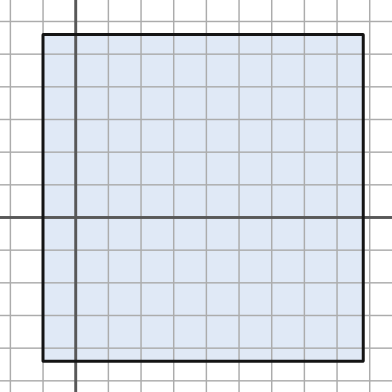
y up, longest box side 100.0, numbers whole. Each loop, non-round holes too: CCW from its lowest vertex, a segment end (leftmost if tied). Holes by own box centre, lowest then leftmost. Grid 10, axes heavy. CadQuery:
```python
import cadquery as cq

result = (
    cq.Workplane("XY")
    .moveTo(-10.0, -44.0)
    .lineTo(88.0, -44.0)
    .lineTo(88.0, 56.0)
    .lineTo(-10.0, 56.0)
    .close()
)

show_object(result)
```